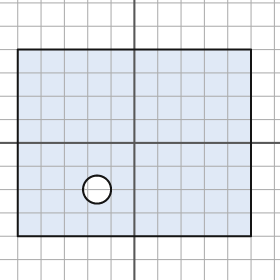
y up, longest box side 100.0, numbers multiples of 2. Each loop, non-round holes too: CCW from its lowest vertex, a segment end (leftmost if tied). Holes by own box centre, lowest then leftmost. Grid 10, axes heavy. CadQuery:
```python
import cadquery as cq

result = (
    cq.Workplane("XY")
    .moveTo(-50.0, -40.0)
    .lineTo(50.0, -40.0)
    .lineTo(50.0, 40.0)
    .lineTo(-50.0, 40.0)
    .close()
    .moveTo(-16.0, -20.0)
    .circle(6.0)
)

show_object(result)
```